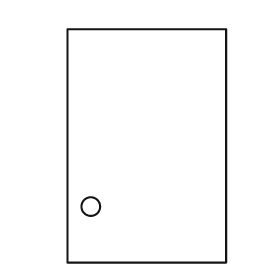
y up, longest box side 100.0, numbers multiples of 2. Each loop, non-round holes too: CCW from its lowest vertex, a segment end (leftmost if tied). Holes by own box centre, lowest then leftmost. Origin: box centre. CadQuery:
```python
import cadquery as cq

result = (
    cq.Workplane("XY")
    .moveTo(-34.0, -50.0)
    .lineTo(34.0, -50.0)
    .lineTo(34.0, 50.0)
    .lineTo(-34.0, 50.0)
    .close()
    .moveTo(-24.0, -26.0)
    .circle(4.0)
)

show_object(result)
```